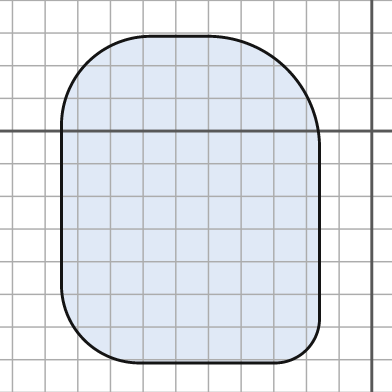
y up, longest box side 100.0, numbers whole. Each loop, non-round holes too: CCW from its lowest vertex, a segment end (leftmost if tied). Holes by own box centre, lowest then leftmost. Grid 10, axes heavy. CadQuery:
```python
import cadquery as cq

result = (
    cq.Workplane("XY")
    .moveTo(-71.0, -71.0)
    .lineTo(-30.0, -71.0)
    .threePointArc((-20.0, -67.0), (-16.0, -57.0))
    .lineTo(-16.0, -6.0)
    .threePointArc((-26.0, 19.0), (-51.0, 29.0))
    .lineTo(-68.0, 29.0)
    .threePointArc((-87.0, 21.0), (-95.0, 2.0))
    .lineTo(-95.0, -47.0)
    .threePointArc((-88.0, -64.0), (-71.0, -71.0))
    .close()
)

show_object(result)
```